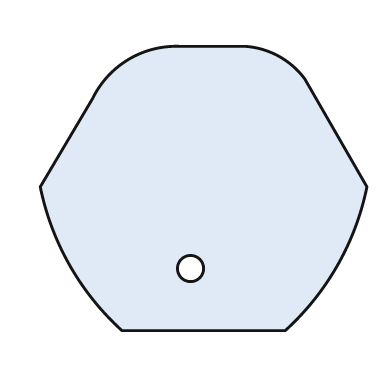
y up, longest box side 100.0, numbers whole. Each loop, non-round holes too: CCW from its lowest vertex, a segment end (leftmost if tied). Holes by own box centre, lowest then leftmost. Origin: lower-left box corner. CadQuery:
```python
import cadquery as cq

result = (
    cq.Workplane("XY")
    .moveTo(25.0, 0.0)
    .lineTo(75.0, 0.0)
    .threePointArc((91.0, 20.0), (100.0, 44.0))
    .lineTo(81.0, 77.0)
    .threePointArc((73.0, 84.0), (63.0, 87.0))
    .lineTo(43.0, 87.0)
    .threePointArc((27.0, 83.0), (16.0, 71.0))
    .lineTo(0.0, 44.0)
    .threePointArc((9.0, 20.0), (25.0, 0.0))
    .close()
    .moveTo(46.0, 19.0)
    .circle(4.0)
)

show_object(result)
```